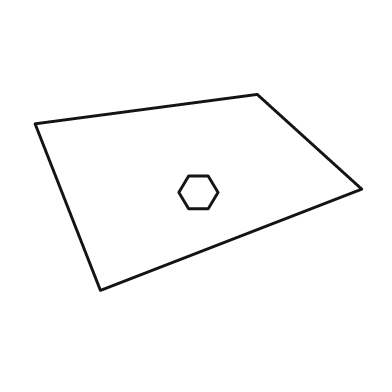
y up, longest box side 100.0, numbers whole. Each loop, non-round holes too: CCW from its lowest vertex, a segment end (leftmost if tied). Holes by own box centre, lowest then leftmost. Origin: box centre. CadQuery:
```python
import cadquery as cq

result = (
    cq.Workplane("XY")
    .moveTo(-30.0, -30.0)
    .lineTo(50.0, 1.0)
    .lineTo(18.0, 30.0)
    .lineTo(-50.0, 21.0)
    .close()
    .moveTo(-3.0, -5.0)
    .lineTo(3.0, -5.0)
    .lineTo(6.0, 0.0)
    .lineTo(3.0, 5.0)
    .lineTo(-3.0, 5.0)
    .lineTo(-6.0, 0.0)
    .close()
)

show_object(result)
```